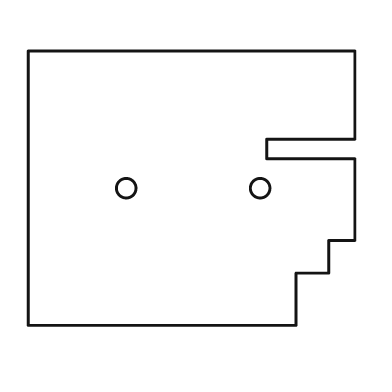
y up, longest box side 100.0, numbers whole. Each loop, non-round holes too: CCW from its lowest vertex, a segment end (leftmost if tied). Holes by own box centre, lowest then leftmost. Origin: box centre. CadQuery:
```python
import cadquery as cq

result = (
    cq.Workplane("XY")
    .moveTo(-50.0, -42.0)
    .lineTo(32.0, -42.0)
    .lineTo(32.0, -26.0)
    .lineTo(42.0, -26.0)
    .lineTo(42.0, -16.0)
    .lineTo(50.0, -16.0)
    .lineTo(50.0, 9.0)
    .lineTo(23.0, 9.0)
    .lineTo(23.0, 15.0)
    .lineTo(50.0, 15.0)
    .lineTo(50.0, 42.0)
    .lineTo(-50.0, 42.0)
    .close()
    .moveTo(-20.0, 0.0)
    .circle(3.0)
    .moveTo(21.0, 0.0)
    .circle(3.0)
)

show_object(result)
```